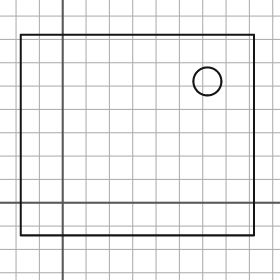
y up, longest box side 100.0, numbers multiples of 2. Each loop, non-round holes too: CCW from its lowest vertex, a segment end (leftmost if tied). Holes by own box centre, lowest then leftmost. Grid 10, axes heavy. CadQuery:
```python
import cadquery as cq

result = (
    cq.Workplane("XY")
    .moveTo(-18.0, -14.0)
    .lineTo(82.0, -14.0)
    .lineTo(82.0, 72.0)
    .lineTo(-18.0, 72.0)
    .close()
    .moveTo(62.0, 52.0)
    .circle(6.0)
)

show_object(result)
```